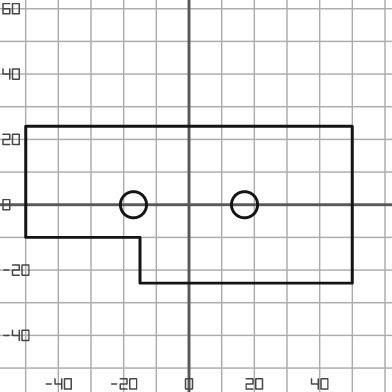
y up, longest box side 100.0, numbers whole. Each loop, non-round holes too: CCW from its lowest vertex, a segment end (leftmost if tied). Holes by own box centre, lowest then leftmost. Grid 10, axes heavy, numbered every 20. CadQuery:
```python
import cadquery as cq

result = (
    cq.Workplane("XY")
    .moveTo(-15.0, -24.0)
    .lineTo(50.0, -24.0)
    .lineTo(50.0, 24.0)
    .lineTo(-50.0, 24.0)
    .lineTo(-50.0, -10.0)
    .lineTo(-15.0, -10.0)
    .close()
    .moveTo(-17.0, 0.0)
    .circle(4.0)
    .moveTo(17.0, 0.0)
    .circle(4.0)
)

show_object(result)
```